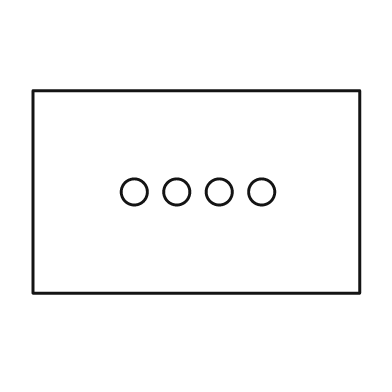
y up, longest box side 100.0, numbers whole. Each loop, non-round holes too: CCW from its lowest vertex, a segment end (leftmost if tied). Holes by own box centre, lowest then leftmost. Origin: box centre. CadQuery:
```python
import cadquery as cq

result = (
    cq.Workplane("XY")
    .moveTo(-50.0, -31.0)
    .lineTo(50.0, -31.0)
    .lineTo(50.0, 31.0)
    .lineTo(-50.0, 31.0)
    .close()
    .moveTo(-19.0, 0.0)
    .circle(4.0)
    .moveTo(-6.0, 0.0)
    .circle(4.0)
    .moveTo(7.0, 0.0)
    .circle(4.0)
    .moveTo(20.0, 0.0)
    .circle(4.0)
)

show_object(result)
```